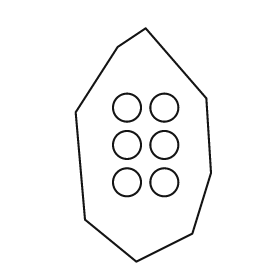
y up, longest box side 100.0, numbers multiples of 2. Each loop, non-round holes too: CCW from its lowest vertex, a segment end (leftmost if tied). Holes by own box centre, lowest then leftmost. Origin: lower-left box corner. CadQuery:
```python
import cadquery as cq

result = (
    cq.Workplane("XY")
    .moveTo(26.0, 0.0)
    .lineTo(50.0, 12.0)
    .lineTo(58.0, 38.0)
    .lineTo(56.0, 70.0)
    .lineTo(30.0, 100.0)
    .lineTo(18.0, 92.0)
    .lineTo(0.0, 64.0)
    .lineTo(4.0, 18.0)
    .close()
    .moveTo(22.0, 34.0)
    .circle(6.0)
    .moveTo(38.0, 34.0)
    .circle(6.0)
    .moveTo(22.0, 50.0)
    .circle(6.0)
    .moveTo(38.0, 50.0)
    .circle(6.0)
    .moveTo(22.0, 66.0)
    .circle(6.0)
    .moveTo(38.0, 66.0)
    .circle(6.0)
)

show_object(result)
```